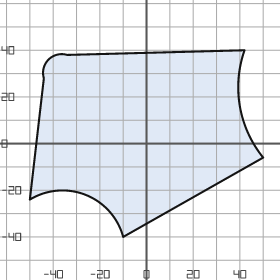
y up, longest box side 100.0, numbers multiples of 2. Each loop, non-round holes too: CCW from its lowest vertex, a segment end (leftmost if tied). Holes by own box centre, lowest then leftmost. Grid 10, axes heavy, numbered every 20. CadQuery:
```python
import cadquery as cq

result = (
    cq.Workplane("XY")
    .moveTo(-10.0, -40.0)
    .lineTo(50.0, -6.0)
    .threePointArc((40.0, 16.0), (42.0, 40.0))
    .lineTo(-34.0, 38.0)
    .threePointArc((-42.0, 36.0), (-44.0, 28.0))
    .lineTo(-50.0, -24.0)
    .threePointArc((-26.0, -22.0), (-10.0, -40.0))
    .close()
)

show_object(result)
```